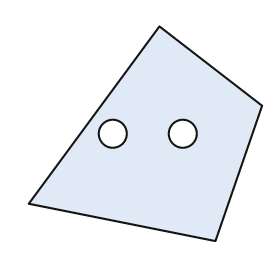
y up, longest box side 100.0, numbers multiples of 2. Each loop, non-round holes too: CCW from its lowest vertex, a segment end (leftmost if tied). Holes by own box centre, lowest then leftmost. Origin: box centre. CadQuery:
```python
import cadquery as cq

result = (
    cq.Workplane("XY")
    .moveTo(30.0, -46.0)
    .lineTo(50.0, 12.0)
    .lineTo(6.0, 46.0)
    .lineTo(-50.0, -30.0)
    .close()
    .moveTo(-14.0, 0.0)
    .circle(6.0)
    .moveTo(16.0, 0.0)
    .circle(6.0)
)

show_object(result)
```